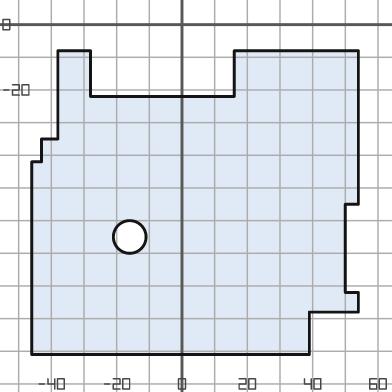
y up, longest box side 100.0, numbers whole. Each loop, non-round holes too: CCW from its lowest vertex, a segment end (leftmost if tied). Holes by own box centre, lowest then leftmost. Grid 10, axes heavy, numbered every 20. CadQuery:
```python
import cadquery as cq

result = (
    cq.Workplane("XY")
    .moveTo(-46.0, -101.0)
    .lineTo(39.0, -101.0)
    .lineTo(39.0, -88.0)
    .lineTo(54.0, -88.0)
    .lineTo(54.0, -82.0)
    .lineTo(50.0, -82.0)
    .lineTo(50.0, -55.0)
    .lineTo(54.0, -55.0)
    .lineTo(54.0, -8.0)
    .lineTo(16.0, -8.0)
    .lineTo(16.0, -22.0)
    .lineTo(-28.0, -22.0)
    .lineTo(-28.0, -8.0)
    .lineTo(-38.0, -8.0)
    .lineTo(-38.0, -35.0)
    .lineTo(-43.0, -35.0)
    .lineTo(-43.0, -42.0)
    .lineTo(-46.0, -42.0)
    .close()
    .moveTo(-16.0, -65.0)
    .circle(5.0)
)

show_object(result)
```